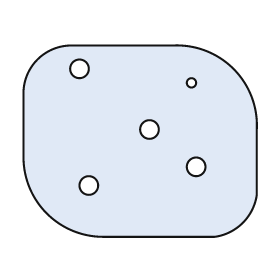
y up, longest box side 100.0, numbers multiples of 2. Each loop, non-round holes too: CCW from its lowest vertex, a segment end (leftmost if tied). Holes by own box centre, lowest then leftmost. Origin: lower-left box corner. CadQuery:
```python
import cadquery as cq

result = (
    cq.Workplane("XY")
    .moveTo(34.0, 0.0)
    .lineTo(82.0, 0.0)
    .threePointArc((94.0, 6.0), (100.0, 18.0))
    .lineTo(100.0, 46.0)
    .threePointArc((90.0, 72.0), (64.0, 82.0))
    .lineTo(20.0, 82.0)
    .threePointArc((6.0, 76.0), (0.0, 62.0))
    .lineTo(0.0, 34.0)
    .threePointArc((10.0, 10.0), (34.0, 0.0))
    .close()
    .moveTo(28.0, 22.0)
    .circle(4.0)
    .moveTo(74.0, 30.0)
    .circle(4.0)
    .moveTo(54.0, 46.0)
    .circle(4.0)
    .moveTo(72.0, 66.0)
    .circle(2.0)
    .moveTo(24.0, 72.0)
    .circle(4.0)
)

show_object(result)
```